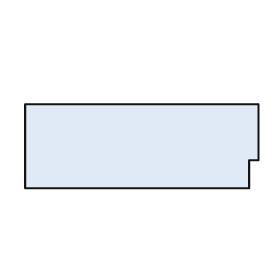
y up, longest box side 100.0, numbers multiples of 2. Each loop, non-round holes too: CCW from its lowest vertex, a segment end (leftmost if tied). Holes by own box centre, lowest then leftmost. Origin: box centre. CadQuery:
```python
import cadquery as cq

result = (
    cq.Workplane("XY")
    .moveTo(-50.0, -18.0)
    .lineTo(46.0, -18.0)
    .lineTo(46.0, -6.0)
    .lineTo(50.0, -6.0)
    .lineTo(50.0, 18.0)
    .lineTo(-50.0, 18.0)
    .close()
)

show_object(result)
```